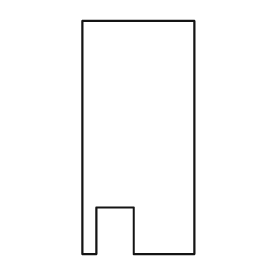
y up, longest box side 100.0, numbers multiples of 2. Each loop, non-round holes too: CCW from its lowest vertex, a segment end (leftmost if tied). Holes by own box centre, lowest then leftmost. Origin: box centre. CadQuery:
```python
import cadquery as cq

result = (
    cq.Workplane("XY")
    .moveTo(-24.0, -50.0)
    .lineTo(-18.0, -50.0)
    .lineTo(-18.0, -30.0)
    .lineTo(-2.0, -30.0)
    .lineTo(-2.0, -50.0)
    .lineTo(24.0, -50.0)
    .lineTo(24.0, 50.0)
    .lineTo(-24.0, 50.0)
    .close()
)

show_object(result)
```